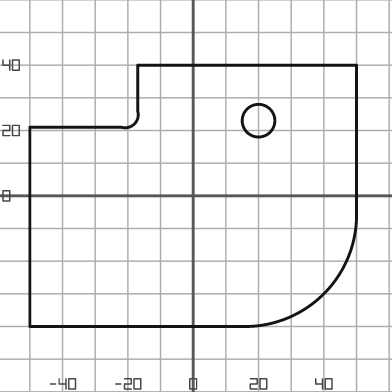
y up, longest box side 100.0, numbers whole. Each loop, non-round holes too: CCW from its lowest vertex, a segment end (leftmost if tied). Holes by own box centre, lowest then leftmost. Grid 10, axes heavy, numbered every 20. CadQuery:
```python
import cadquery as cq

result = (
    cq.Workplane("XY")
    .moveTo(-50.0, -40.0)
    .lineTo(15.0, -40.0)
    .threePointArc((40.0, -30.0), (50.0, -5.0))
    .lineTo(50.0, 40.0)
    .lineTo(-17.0, 40.0)
    .lineTo(-17.0, 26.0)
    .threePointArc((-18.0, 22.0), (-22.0, 21.0))
    .lineTo(-50.0, 21.0)
    .close()
    .moveTo(20.0, 23.0)
    .circle(5.0)
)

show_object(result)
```